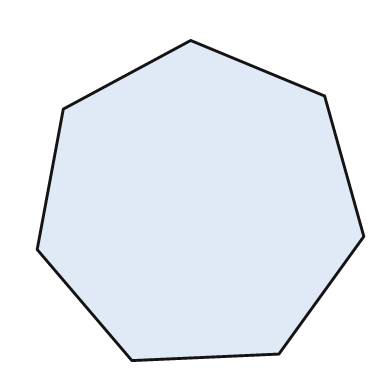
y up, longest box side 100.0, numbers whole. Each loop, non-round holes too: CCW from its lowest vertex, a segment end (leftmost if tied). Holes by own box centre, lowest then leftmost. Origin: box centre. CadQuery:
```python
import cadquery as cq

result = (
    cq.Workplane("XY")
    .moveTo(-21.0, -49.0)
    .lineTo(24.0, -47.0)
    .lineTo(50.0, -11.0)
    .lineTo(38.0, 32.0)
    .lineTo(-3.0, 49.0)
    .lineTo(-42.0, 28.0)
    .lineTo(-50.0, -15.0)
    .close()
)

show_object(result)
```